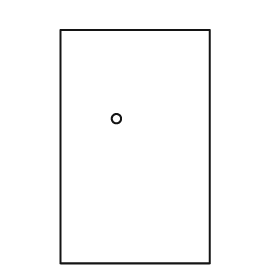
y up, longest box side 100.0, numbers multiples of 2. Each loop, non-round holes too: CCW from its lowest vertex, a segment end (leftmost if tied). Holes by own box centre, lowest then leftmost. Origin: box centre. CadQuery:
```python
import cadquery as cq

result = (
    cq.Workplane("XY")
    .moveTo(-32.0, -50.0)
    .lineTo(32.0, -50.0)
    .lineTo(32.0, 50.0)
    .lineTo(-32.0, 50.0)
    .close()
    .moveTo(-8.0, 12.0)
    .circle(2.0)
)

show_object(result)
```